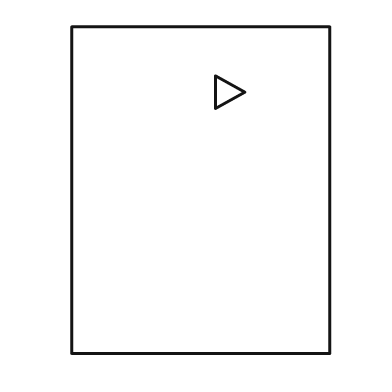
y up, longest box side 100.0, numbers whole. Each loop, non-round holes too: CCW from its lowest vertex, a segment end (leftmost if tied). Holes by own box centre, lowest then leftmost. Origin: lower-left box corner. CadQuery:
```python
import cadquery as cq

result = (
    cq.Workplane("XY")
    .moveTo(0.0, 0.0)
    .lineTo(79.0, 0.0)
    .lineTo(79.0, 100.0)
    .lineTo(0.0, 100.0)
    .close()
    .moveTo(44.0, 75.0)
    .lineTo(53.0, 80.0)
    .lineTo(44.0, 85.0)
    .close()
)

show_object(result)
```